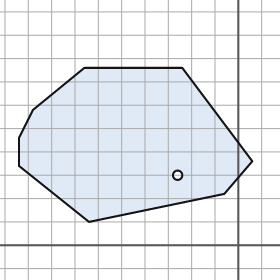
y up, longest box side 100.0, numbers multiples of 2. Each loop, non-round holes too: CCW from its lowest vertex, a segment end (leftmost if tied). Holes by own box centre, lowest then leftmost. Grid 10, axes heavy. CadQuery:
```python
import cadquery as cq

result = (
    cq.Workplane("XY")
    .moveTo(-64.0, 10.0)
    .lineTo(-6.0, 22.0)
    .lineTo(6.0, 36.0)
    .lineTo(-24.0, 76.0)
    .lineTo(-66.0, 76.0)
    .lineTo(-88.0, 58.0)
    .lineTo(-94.0, 46.0)
    .lineTo(-94.0, 34.0)
    .close()
    .moveTo(-26.0, 30.0)
    .circle(2.0)
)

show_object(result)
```